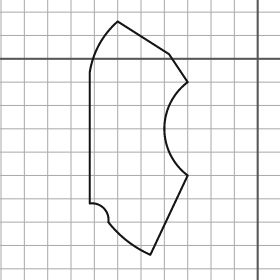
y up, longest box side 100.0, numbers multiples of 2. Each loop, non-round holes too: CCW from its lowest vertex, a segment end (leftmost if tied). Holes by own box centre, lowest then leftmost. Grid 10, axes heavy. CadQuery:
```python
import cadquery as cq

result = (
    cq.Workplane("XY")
    .moveTo(-46.0, -84.0)
    .lineTo(-30.0, -50.0)
    .threePointArc((-40.0, -30.0), (-30.0, -10.0))
    .lineTo(-38.0, 2.0)
    .lineTo(-60.0, 16.0)
    .threePointArc((-68.0, 6.0), (-72.0, -6.0))
    .lineTo(-72.0, -62.0)
    .threePointArc((-66.0, -64.0), (-64.0, -70.0))
    .threePointArc((-56.0, -78.0), (-46.0, -84.0))
    .close()
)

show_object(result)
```